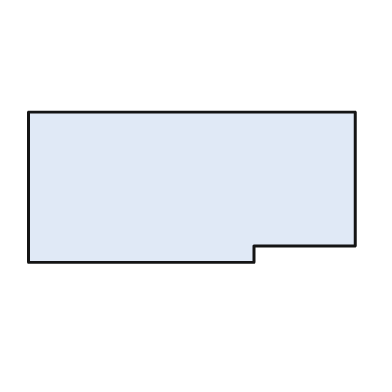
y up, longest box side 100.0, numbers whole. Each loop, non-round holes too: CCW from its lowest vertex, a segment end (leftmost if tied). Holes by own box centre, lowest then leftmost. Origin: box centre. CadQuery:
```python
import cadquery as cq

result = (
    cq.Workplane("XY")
    .moveTo(-50.0, -23.0)
    .lineTo(19.0, -23.0)
    .lineTo(19.0, -18.0)
    .lineTo(50.0, -18.0)
    .lineTo(50.0, 23.0)
    .lineTo(-50.0, 23.0)
    .close()
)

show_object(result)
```